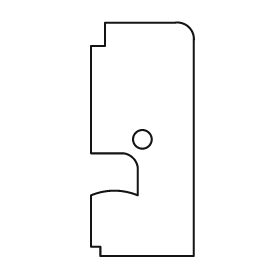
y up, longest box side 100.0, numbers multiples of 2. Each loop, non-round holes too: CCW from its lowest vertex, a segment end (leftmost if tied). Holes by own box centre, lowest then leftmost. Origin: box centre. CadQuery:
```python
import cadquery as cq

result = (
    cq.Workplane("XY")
    .moveTo(-18.0, -50.0)
    .lineTo(22.0, -50.0)
    .lineTo(22.0, 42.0)
    .threePointArc((20.0, 48.0), (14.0, 50.0))
    .lineTo(-16.0, 50.0)
    .lineTo(-16.0, 40.0)
    .lineTo(-22.0, 40.0)
    .lineTo(-22.0, -6.0)
    .lineTo(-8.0, -6.0)
    .threePointArc((-4.0, -8.0), (-2.0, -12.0))
    .lineTo(-2.0, -24.0)
    .threePointArc((-12.0, -22.0), (-22.0, -24.0))
    .lineTo(-22.0, -46.0)
    .lineTo(-18.0, -46.0)
    .close()
    .moveTo(0.0, 0.0)
    .circle(4.0)
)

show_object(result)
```